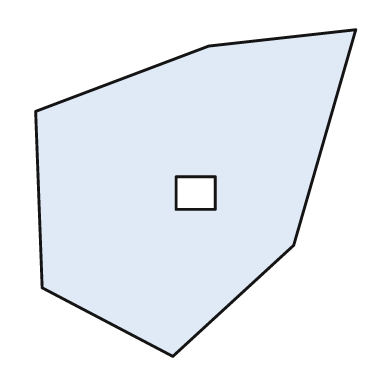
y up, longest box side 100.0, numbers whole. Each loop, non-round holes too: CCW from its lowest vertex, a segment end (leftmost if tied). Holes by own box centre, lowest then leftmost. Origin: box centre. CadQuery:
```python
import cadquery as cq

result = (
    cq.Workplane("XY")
    .moveTo(-7.0, -50.0)
    .lineTo(30.0, -16.0)
    .lineTo(49.0, 50.0)
    .lineTo(4.0, 45.0)
    .lineTo(-49.0, 25.0)
    .lineTo(-47.0, -29.0)
    .close()
    .moveTo(-6.0, -5.0)
    .lineTo(6.0, -5.0)
    .lineTo(6.0, 5.0)
    .lineTo(-6.0, 5.0)
    .close()
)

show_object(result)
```